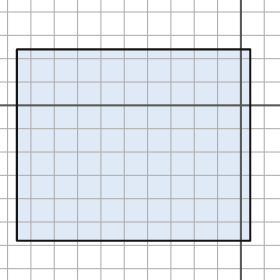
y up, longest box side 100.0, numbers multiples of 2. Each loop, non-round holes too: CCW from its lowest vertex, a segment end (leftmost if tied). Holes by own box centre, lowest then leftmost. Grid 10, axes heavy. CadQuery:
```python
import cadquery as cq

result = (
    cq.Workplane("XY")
    .moveTo(-96.0, -58.0)
    .lineTo(4.0, -58.0)
    .lineTo(4.0, 24.0)
    .lineTo(-96.0, 24.0)
    .close()
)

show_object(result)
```